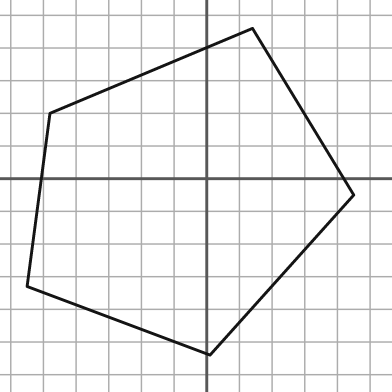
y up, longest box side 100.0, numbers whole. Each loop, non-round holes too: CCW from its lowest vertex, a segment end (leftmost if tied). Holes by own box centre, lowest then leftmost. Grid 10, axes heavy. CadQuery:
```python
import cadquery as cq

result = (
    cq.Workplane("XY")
    .moveTo(1.0, -54.0)
    .lineTo(45.0, -5.0)
    .lineTo(14.0, 46.0)
    .lineTo(-48.0, 20.0)
    .lineTo(-55.0, -33.0)
    .close()
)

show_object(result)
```